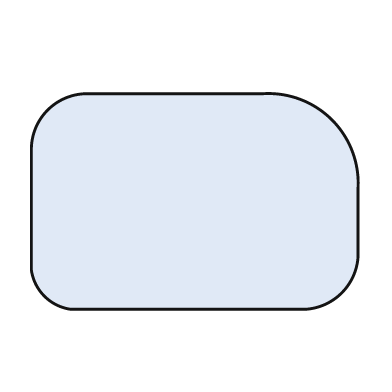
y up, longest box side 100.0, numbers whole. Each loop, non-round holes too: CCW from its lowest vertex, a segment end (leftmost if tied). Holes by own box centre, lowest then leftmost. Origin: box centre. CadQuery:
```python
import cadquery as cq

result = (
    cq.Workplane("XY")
    .moveTo(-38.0, -33.0)
    .lineTo(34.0, -33.0)
    .threePointArc((45.0, -28.0), (50.0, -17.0))
    .lineTo(50.0, 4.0)
    .threePointArc((42.0, 25.0), (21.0, 33.0))
    .lineTo(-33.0, 33.0)
    .threePointArc((-45.0, 28.0), (-50.0, 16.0))
    .lineTo(-50.0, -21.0)
    .threePointArc((-46.0, -29.0), (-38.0, -33.0))
    .close()
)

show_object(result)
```